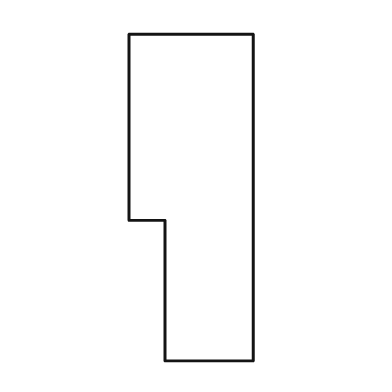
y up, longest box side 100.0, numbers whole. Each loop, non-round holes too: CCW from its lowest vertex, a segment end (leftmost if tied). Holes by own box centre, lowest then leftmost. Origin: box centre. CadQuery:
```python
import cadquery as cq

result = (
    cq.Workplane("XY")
    .moveTo(-8.0, -50.0)
    .lineTo(19.0, -50.0)
    .lineTo(19.0, 50.0)
    .lineTo(-19.0, 50.0)
    .lineTo(-19.0, -7.0)
    .lineTo(-8.0, -7.0)
    .close()
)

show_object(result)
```